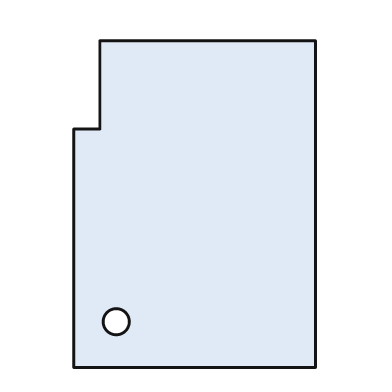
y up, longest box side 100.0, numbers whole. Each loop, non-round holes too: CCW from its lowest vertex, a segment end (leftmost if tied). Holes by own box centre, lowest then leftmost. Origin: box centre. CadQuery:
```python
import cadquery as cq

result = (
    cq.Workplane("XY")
    .moveTo(-37.0, -50.0)
    .lineTo(37.0, -50.0)
    .lineTo(37.0, 50.0)
    .lineTo(-29.0, 50.0)
    .lineTo(-29.0, 23.0)
    .lineTo(-37.0, 23.0)
    .close()
    .moveTo(-24.0, -36.0)
    .circle(4.0)
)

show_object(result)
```